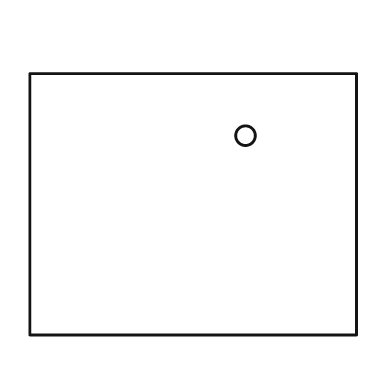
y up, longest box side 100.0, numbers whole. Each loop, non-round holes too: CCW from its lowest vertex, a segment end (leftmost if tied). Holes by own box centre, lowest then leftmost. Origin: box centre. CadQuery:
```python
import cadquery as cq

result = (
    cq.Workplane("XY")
    .moveTo(-50.0, -40.0)
    .lineTo(50.0, -40.0)
    .lineTo(50.0, 40.0)
    .lineTo(-50.0, 40.0)
    .close()
    .moveTo(16.0, 21.0)
    .circle(3.0)
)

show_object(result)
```